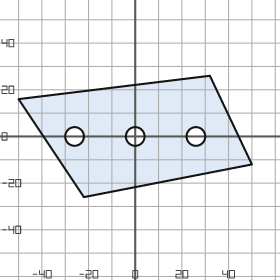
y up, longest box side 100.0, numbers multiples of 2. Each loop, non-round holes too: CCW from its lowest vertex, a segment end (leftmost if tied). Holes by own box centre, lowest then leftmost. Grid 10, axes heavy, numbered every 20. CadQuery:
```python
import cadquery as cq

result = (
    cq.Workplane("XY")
    .moveTo(-22.0, -26.0)
    .lineTo(50.0, -12.0)
    .lineTo(32.0, 26.0)
    .lineTo(-50.0, 16.0)
    .close()
    .moveTo(-26.0, 0.0)
    .circle(4.0)
    .moveTo(0.0, 0.0)
    .circle(4.0)
    .moveTo(26.0, 0.0)
    .circle(4.0)
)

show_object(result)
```